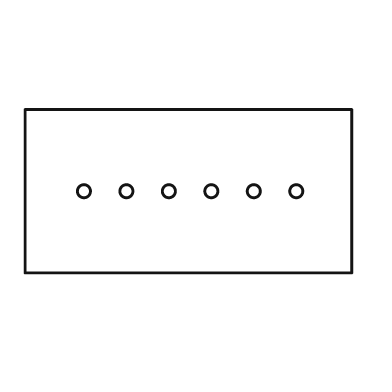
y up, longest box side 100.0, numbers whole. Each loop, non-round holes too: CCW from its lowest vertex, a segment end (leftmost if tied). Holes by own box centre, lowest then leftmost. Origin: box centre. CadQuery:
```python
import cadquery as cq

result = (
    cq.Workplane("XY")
    .moveTo(-50.0, -25.0)
    .lineTo(50.0, -25.0)
    .lineTo(50.0, 25.0)
    .lineTo(-50.0, 25.0)
    .close()
    .moveTo(-32.0, 0.0)
    .circle(2.0)
    .moveTo(-19.0, 0.0)
    .circle(2.0)
    .moveTo(-6.0, 0.0)
    .circle(2.0)
    .moveTo(7.0, 0.0)
    .circle(2.0)
    .moveTo(20.0, 0.0)
    .circle(2.0)
    .moveTo(33.0, 0.0)
    .circle(2.0)
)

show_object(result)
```